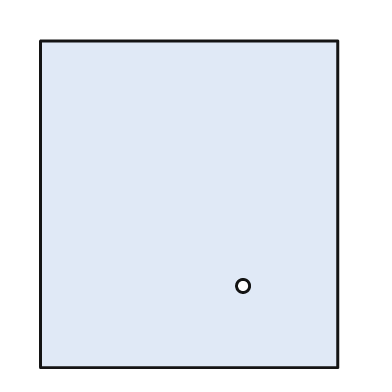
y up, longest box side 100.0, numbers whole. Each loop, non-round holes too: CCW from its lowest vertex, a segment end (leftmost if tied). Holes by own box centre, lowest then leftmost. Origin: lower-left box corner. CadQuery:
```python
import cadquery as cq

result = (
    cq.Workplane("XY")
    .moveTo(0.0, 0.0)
    .lineTo(91.0, 0.0)
    .lineTo(91.0, 100.0)
    .lineTo(0.0, 100.0)
    .close()
    .moveTo(62.0, 25.0)
    .circle(2.0)
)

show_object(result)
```